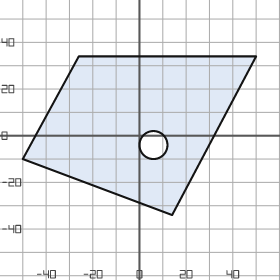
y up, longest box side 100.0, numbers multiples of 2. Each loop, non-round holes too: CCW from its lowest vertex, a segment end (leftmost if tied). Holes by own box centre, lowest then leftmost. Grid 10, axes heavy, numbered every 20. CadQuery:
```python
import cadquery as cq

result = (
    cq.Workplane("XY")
    .moveTo(14.0, -34.0)
    .lineTo(50.0, 34.0)
    .lineTo(-26.0, 34.0)
    .lineTo(-50.0, -10.0)
    .close()
    .moveTo(6.0, -4.0)
    .circle(6.0)
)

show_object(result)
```